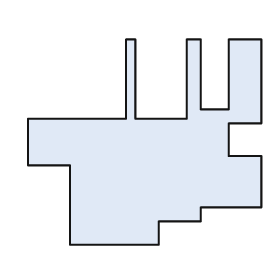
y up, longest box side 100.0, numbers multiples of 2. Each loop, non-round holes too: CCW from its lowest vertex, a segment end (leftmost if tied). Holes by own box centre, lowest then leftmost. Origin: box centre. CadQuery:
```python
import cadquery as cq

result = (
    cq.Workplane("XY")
    .moveTo(-32.0, -44.0)
    .lineTo(6.0, -44.0)
    .lineTo(6.0, -34.0)
    .lineTo(24.0, -34.0)
    .lineTo(24.0, -28.0)
    .lineTo(50.0, -28.0)
    .lineTo(50.0, -6.0)
    .lineTo(36.0, -6.0)
    .lineTo(36.0, 8.0)
    .lineTo(50.0, 8.0)
    .lineTo(50.0, 44.0)
    .lineTo(36.0, 44.0)
    .lineTo(36.0, 14.0)
    .lineTo(24.0, 14.0)
    .lineTo(24.0, 44.0)
    .lineTo(18.0, 44.0)
    .lineTo(18.0, 10.0)
    .lineTo(-4.0, 10.0)
    .lineTo(-4.0, 44.0)
    .lineTo(-8.0, 44.0)
    .lineTo(-8.0, 10.0)
    .lineTo(-50.0, 10.0)
    .lineTo(-50.0, -10.0)
    .lineTo(-32.0, -10.0)
    .close()
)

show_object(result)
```